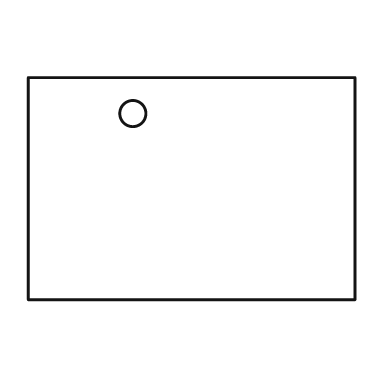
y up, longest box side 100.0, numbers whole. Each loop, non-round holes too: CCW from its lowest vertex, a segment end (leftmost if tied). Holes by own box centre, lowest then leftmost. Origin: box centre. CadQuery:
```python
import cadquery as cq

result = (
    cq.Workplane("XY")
    .moveTo(-50.0, -34.0)
    .lineTo(50.0, -34.0)
    .lineTo(50.0, 34.0)
    .lineTo(-50.0, 34.0)
    .close()
    .moveTo(-18.0, 23.0)
    .circle(4.0)
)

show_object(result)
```